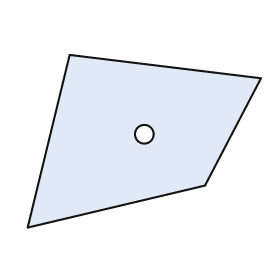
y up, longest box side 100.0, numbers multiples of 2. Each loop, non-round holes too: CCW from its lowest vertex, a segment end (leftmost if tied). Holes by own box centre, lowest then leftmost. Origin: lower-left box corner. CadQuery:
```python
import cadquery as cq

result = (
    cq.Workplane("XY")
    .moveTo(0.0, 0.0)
    .lineTo(76.0, 18.0)
    .lineTo(100.0, 64.0)
    .lineTo(18.0, 74.0)
    .close()
    .moveTo(50.0, 40.0)
    .circle(4.0)
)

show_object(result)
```